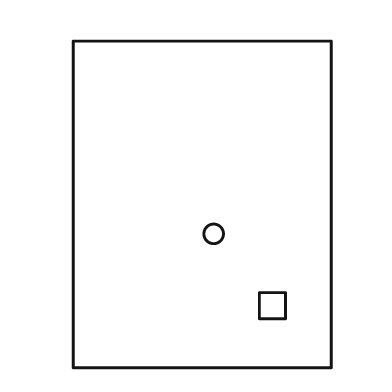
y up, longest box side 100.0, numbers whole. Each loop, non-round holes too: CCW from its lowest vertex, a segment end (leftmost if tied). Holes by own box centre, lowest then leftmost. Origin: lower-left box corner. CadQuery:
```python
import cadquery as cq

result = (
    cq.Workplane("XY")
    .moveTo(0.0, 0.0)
    .lineTo(79.0, 0.0)
    .lineTo(79.0, 100.0)
    .lineTo(0.0, 100.0)
    .close()
    .moveTo(57.0, 15.0)
    .lineTo(65.0, 15.0)
    .lineTo(65.0, 23.0)
    .lineTo(57.0, 23.0)
    .close()
    .moveTo(43.0, 41.0)
    .circle(3.0)
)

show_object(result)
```